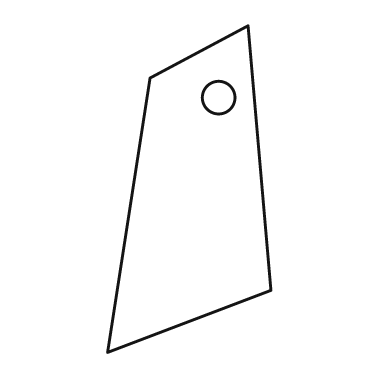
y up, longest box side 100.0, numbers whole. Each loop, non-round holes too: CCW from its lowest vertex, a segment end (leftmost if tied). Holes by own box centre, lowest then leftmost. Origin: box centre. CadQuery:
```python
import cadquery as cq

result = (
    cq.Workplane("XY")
    .moveTo(-25.0, -50.0)
    .lineTo(25.0, -31.0)
    .lineTo(18.0, 50.0)
    .lineTo(-12.0, 34.0)
    .close()
    .moveTo(9.0, 28.0)
    .circle(5.0)
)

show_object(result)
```